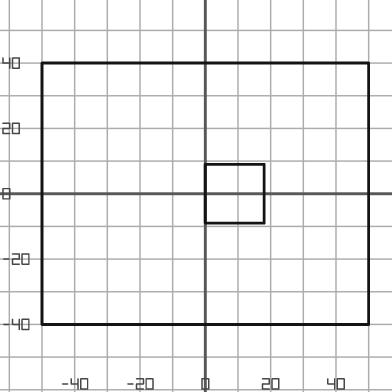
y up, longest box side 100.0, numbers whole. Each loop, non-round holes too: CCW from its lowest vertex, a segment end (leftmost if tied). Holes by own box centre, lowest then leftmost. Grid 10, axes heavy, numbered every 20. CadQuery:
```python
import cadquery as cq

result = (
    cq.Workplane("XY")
    .moveTo(-50.0, -40.0)
    .lineTo(50.0, -40.0)
    .lineTo(50.0, 40.0)
    .lineTo(-50.0, 40.0)
    .close()
    .moveTo(0.0, -9.0)
    .lineTo(18.0, -9.0)
    .lineTo(18.0, 9.0)
    .lineTo(0.0, 9.0)
    .close()
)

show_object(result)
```